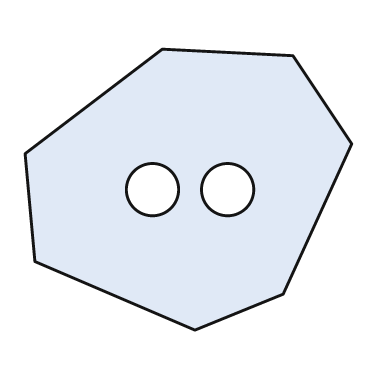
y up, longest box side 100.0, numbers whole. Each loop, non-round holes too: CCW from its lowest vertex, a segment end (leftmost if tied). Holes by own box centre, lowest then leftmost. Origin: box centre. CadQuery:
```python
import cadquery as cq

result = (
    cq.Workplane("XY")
    .moveTo(2.0, -43.0)
    .lineTo(29.0, -32.0)
    .lineTo(50.0, 14.0)
    .lineTo(32.0, 41.0)
    .lineTo(-8.0, 43.0)
    .lineTo(-50.0, 11.0)
    .lineTo(-47.0, -22.0)
    .close()
    .moveTo(-11.0, 0.0)
    .circle(8.0)
    .moveTo(12.0, 0.0)
    .circle(8.0)
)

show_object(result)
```